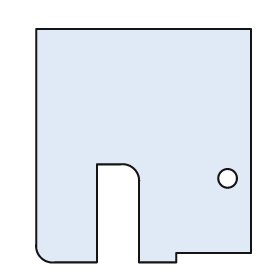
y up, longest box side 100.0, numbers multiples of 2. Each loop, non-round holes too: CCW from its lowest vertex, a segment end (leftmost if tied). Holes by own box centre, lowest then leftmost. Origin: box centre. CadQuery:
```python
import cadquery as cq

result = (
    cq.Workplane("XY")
    .moveTo(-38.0, -50.0)
    .lineTo(-20.0, -50.0)
    .lineTo(-20.0, -8.0)
    .lineTo(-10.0, -8.0)
    .threePointArc((-4.0, -10.0), (-2.0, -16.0))
    .lineTo(-2.0, -50.0)
    .lineTo(14.0, -50.0)
    .lineTo(14.0, -46.0)
    .lineTo(46.0, -46.0)
    .lineTo(46.0, 50.0)
    .lineTo(-46.0, 50.0)
    .lineTo(-46.0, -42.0)
    .threePointArc((-44.0, -48.0), (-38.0, -50.0))
    .close()
    .moveTo(36.0, -14.0)
    .circle(4.0)
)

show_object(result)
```